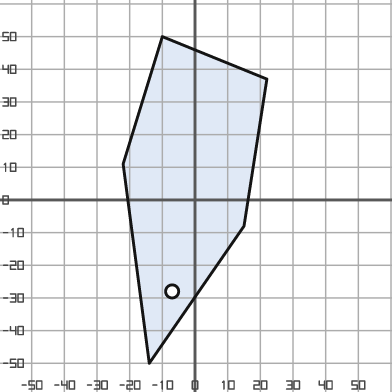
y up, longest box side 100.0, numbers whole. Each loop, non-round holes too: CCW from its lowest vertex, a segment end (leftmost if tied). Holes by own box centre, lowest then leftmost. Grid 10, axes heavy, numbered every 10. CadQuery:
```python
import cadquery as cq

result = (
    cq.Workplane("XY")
    .moveTo(-14.0, -50.0)
    .lineTo(15.0, -8.0)
    .lineTo(22.0, 37.0)
    .lineTo(-10.0, 50.0)
    .lineTo(-22.0, 11.0)
    .close()
    .moveTo(-7.0, -28.0)
    .circle(2.0)
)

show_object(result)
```